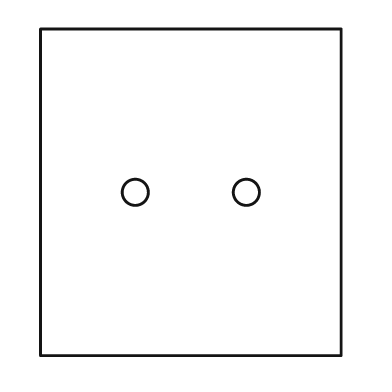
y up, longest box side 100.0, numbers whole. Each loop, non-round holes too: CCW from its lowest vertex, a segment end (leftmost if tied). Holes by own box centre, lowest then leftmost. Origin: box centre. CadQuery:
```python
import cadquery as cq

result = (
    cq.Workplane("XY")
    .moveTo(-46.0, -50.0)
    .lineTo(46.0, -50.0)
    .lineTo(46.0, 50.0)
    .lineTo(-46.0, 50.0)
    .close()
    .moveTo(-17.0, 0.0)
    .circle(4.0)
    .moveTo(17.0, 0.0)
    .circle(4.0)
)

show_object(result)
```